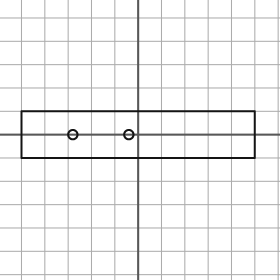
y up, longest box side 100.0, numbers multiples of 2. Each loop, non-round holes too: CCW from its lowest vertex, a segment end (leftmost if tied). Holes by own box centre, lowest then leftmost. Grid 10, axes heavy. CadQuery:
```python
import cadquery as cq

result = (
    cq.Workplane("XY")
    .moveTo(-50.0, -10.0)
    .lineTo(50.0, -10.0)
    .lineTo(50.0, 10.0)
    .lineTo(-50.0, 10.0)
    .close()
    .moveTo(-28.0, 0.0)
    .circle(2.0)
    .moveTo(-4.0, 0.0)
    .circle(2.0)
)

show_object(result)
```